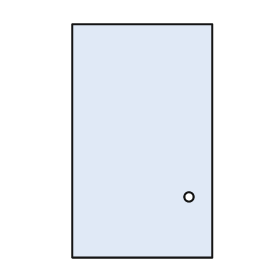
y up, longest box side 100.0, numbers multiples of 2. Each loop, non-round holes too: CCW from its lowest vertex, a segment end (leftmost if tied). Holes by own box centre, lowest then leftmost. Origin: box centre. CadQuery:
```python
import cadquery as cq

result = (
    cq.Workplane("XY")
    .moveTo(-30.0, -50.0)
    .lineTo(30.0, -50.0)
    .lineTo(30.0, 50.0)
    .lineTo(-30.0, 50.0)
    .close()
    .moveTo(20.0, -24.0)
    .circle(2.0)
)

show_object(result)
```